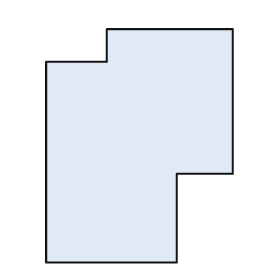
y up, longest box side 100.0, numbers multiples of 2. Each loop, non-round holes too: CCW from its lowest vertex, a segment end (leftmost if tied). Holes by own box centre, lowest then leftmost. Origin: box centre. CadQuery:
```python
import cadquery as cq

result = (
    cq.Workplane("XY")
    .moveTo(-40.0, -50.0)
    .lineTo(16.0, -50.0)
    .lineTo(16.0, -12.0)
    .lineTo(40.0, -12.0)
    .lineTo(40.0, 50.0)
    .lineTo(-14.0, 50.0)
    .lineTo(-14.0, 36.0)
    .lineTo(-40.0, 36.0)
    .close()
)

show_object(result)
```